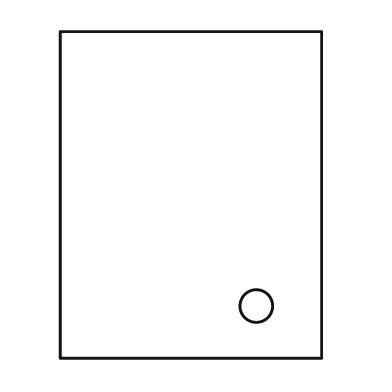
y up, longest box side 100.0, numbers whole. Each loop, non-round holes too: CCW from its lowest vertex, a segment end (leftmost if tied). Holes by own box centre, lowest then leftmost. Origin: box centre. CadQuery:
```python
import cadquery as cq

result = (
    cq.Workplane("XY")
    .moveTo(-40.0, -50.0)
    .lineTo(40.0, -50.0)
    .lineTo(40.0, 50.0)
    .lineTo(-40.0, 50.0)
    .close()
    .moveTo(20.0, -34.0)
    .circle(5.0)
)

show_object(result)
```